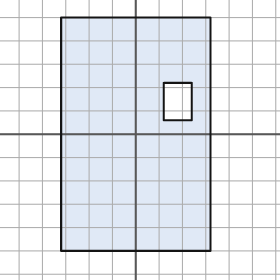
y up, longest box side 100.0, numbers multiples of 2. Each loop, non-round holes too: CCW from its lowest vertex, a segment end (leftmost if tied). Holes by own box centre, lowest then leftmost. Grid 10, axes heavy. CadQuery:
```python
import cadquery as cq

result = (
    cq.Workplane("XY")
    .moveTo(-32.0, -50.0)
    .lineTo(32.0, -50.0)
    .lineTo(32.0, 50.0)
    .lineTo(-32.0, 50.0)
    .close()
    .moveTo(12.0, 6.0)
    .lineTo(24.0, 6.0)
    .lineTo(24.0, 22.0)
    .lineTo(12.0, 22.0)
    .close()
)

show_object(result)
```